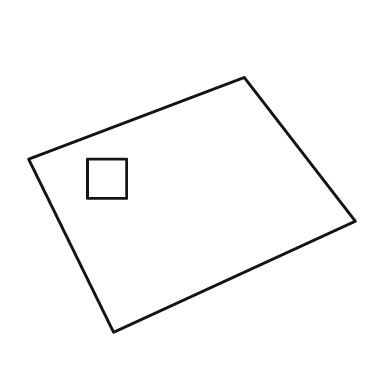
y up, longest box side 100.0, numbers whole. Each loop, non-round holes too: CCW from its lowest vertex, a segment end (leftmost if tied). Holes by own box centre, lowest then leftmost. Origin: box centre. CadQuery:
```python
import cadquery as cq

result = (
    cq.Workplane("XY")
    .moveTo(-24.0, -39.0)
    .lineTo(50.0, -5.0)
    .lineTo(16.0, 39.0)
    .lineTo(-50.0, 14.0)
    .close()
    .moveTo(-32.0, 2.0)
    .lineTo(-20.0, 2.0)
    .lineTo(-20.0, 14.0)
    .lineTo(-32.0, 14.0)
    .close()
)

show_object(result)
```